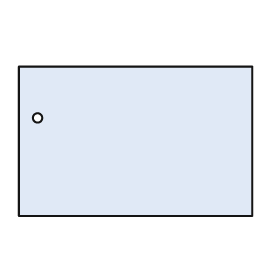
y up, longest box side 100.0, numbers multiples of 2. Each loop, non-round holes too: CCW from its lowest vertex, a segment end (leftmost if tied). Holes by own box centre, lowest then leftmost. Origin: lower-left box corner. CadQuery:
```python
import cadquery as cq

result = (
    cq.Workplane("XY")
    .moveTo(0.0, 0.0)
    .lineTo(100.0, 0.0)
    .lineTo(100.0, 64.0)
    .lineTo(0.0, 64.0)
    .close()
    .moveTo(8.0, 42.0)
    .circle(2.0)
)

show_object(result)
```